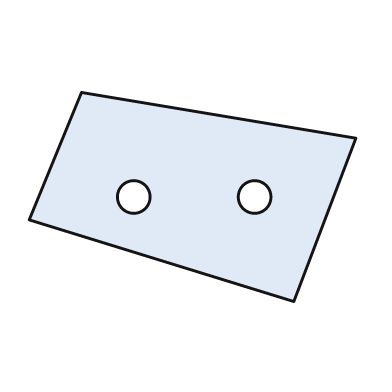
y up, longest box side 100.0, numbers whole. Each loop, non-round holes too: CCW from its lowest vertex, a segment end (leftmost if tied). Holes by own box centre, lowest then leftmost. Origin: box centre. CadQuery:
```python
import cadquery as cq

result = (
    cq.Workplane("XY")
    .moveTo(31.0, -32.0)
    .lineTo(50.0, 18.0)
    .lineTo(-34.0, 32.0)
    .lineTo(-50.0, -7.0)
    .close()
    .moveTo(-18.0, 0.0)
    .circle(5.0)
    .moveTo(19.0, 0.0)
    .circle(5.0)
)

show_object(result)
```